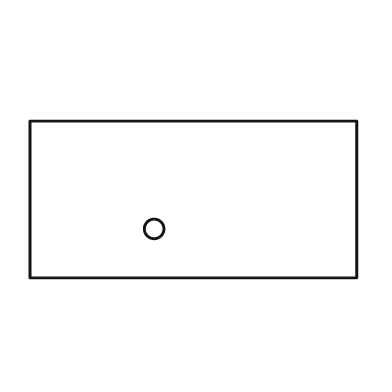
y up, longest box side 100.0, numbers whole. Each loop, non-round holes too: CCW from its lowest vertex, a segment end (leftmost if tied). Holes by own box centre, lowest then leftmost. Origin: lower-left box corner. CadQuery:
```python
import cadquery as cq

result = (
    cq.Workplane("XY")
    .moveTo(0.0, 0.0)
    .lineTo(100.0, 0.0)
    .lineTo(100.0, 48.0)
    .lineTo(0.0, 48.0)
    .close()
    .moveTo(38.0, 15.0)
    .circle(3.0)
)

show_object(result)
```